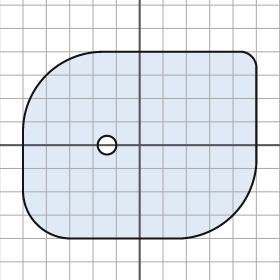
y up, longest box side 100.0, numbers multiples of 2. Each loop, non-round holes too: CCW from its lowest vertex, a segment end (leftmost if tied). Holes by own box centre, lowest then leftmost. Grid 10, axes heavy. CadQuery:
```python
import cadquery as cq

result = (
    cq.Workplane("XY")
    .moveTo(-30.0, -40.0)
    .lineTo(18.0, -40.0)
    .threePointArc((40.0, -30.0), (50.0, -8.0))
    .lineTo(50.0, 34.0)
    .threePointArc((48.0, 38.0), (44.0, 40.0))
    .lineTo(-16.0, 40.0)
    .threePointArc((-40.0, 30.0), (-50.0, 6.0))
    .lineTo(-50.0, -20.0)
    .threePointArc((-44.0, -34.0), (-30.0, -40.0))
    .close()
    .moveTo(-14.0, 0.0)
    .circle(4.0)
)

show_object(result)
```